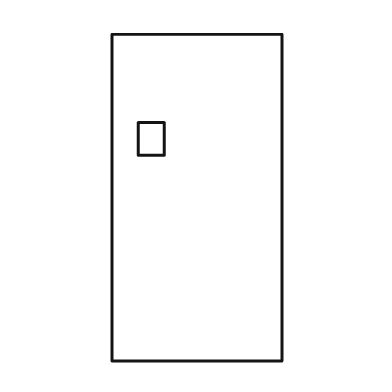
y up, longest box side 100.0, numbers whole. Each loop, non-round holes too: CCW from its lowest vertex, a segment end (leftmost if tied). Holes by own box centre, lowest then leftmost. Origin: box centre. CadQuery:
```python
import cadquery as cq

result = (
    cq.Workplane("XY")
    .moveTo(-26.0, -50.0)
    .lineTo(26.0, -50.0)
    .lineTo(26.0, 50.0)
    .lineTo(-26.0, 50.0)
    .close()
    .moveTo(-18.0, 13.0)
    .lineTo(-10.0, 13.0)
    .lineTo(-10.0, 23.0)
    .lineTo(-18.0, 23.0)
    .close()
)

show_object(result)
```